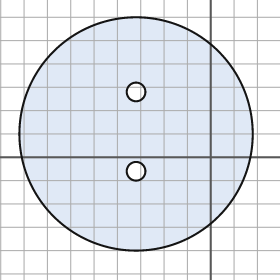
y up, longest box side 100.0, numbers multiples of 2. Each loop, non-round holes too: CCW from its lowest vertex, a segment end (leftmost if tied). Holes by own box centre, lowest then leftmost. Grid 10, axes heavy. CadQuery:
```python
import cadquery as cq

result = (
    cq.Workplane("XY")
    .moveTo(-32.0, 10.0)
    .circle(50.0)
    .moveTo(-32.0, -6.0)
    .circle(4.0)
    .moveTo(-32.0, 28.0)
    .circle(4.0)
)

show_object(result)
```